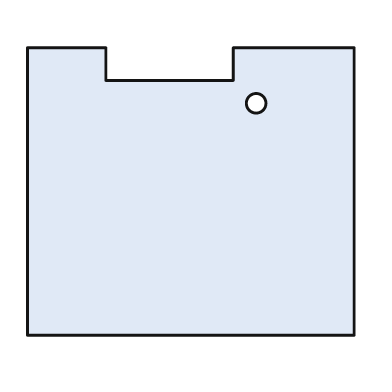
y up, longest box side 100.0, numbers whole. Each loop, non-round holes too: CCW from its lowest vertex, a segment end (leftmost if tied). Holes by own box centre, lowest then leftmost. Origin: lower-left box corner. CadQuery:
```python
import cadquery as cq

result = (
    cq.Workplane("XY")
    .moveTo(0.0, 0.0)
    .lineTo(100.0, 0.0)
    .lineTo(100.0, 88.0)
    .lineTo(63.0, 88.0)
    .lineTo(63.0, 78.0)
    .lineTo(24.0, 78.0)
    .lineTo(24.0, 88.0)
    .lineTo(0.0, 88.0)
    .close()
    .moveTo(70.0, 71.0)
    .circle(3.0)
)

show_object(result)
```